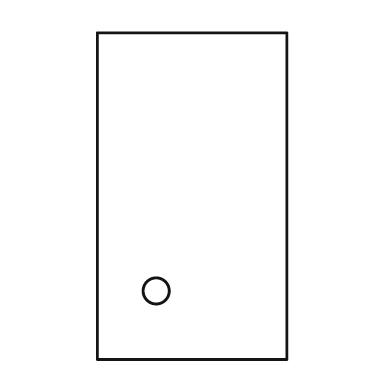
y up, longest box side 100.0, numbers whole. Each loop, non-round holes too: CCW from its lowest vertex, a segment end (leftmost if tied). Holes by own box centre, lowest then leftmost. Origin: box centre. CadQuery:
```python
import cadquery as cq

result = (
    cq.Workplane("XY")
    .moveTo(-29.0, -50.0)
    .lineTo(29.0, -50.0)
    .lineTo(29.0, 50.0)
    .lineTo(-29.0, 50.0)
    .close()
    .moveTo(-11.0, -29.0)
    .circle(4.0)
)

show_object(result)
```